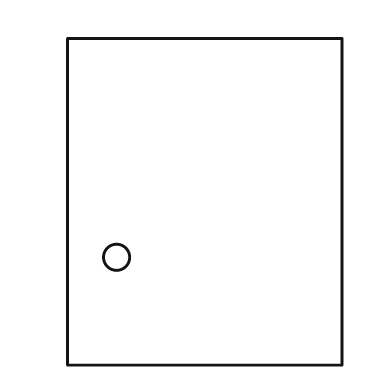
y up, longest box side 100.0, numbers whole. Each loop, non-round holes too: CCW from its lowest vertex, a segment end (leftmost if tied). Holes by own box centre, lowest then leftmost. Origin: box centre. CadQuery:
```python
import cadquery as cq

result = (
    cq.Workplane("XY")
    .moveTo(-42.0, -50.0)
    .lineTo(42.0, -50.0)
    .lineTo(42.0, 50.0)
    .lineTo(-42.0, 50.0)
    .close()
    .moveTo(-27.0, -17.0)
    .circle(4.0)
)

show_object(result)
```